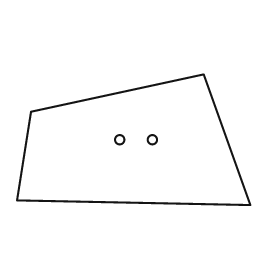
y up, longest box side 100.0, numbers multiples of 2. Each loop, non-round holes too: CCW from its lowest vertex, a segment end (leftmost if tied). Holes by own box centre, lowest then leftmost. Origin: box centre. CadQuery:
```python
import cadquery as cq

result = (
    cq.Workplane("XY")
    .moveTo(50.0, -28.0)
    .lineTo(30.0, 28.0)
    .lineTo(-44.0, 12.0)
    .lineTo(-50.0, -26.0)
    .close()
    .moveTo(-6.0, 0.0)
    .circle(2.0)
    .moveTo(8.0, 0.0)
    .circle(2.0)
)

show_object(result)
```